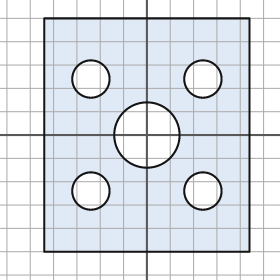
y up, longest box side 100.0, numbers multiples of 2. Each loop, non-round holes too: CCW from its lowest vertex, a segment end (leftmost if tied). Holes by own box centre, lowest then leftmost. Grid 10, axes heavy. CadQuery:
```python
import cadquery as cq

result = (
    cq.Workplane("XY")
    .moveTo(-44.0, -50.0)
    .lineTo(44.0, -50.0)
    .lineTo(44.0, 50.0)
    .lineTo(-44.0, 50.0)
    .close()
    .moveTo(-24.0, -24.0)
    .circle(8.0)
    .moveTo(24.0, -24.0)
    .circle(8.0)
    .moveTo(0.0, 0.0)
    .circle(14.0)
    .moveTo(-24.0, 24.0)
    .circle(8.0)
    .moveTo(24.0, 24.0)
    .circle(8.0)
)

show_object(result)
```